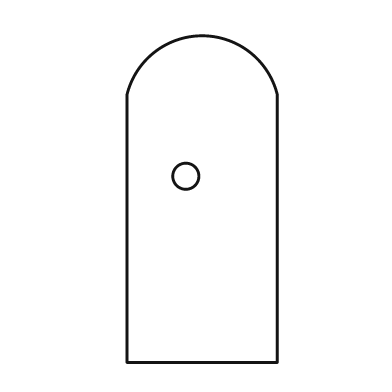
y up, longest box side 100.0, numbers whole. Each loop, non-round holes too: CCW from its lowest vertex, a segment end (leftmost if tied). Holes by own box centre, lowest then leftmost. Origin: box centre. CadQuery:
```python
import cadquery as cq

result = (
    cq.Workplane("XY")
    .moveTo(-23.0, -50.0)
    .lineTo(23.0, -50.0)
    .lineTo(23.0, 32.0)
    .threePointArc((0.0, 50.0), (-23.0, 32.0))
    .close()
    .moveTo(-5.0, 7.0)
    .circle(4.0)
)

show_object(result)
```